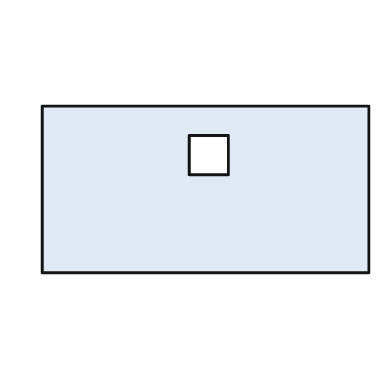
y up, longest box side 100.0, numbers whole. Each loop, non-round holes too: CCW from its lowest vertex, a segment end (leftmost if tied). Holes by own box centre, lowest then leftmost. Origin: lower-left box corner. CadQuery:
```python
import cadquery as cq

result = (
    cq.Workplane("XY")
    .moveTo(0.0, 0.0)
    .lineTo(100.0, 0.0)
    .lineTo(100.0, 51.0)
    .lineTo(0.0, 51.0)
    .close()
    .moveTo(45.0, 30.0)
    .lineTo(57.0, 30.0)
    .lineTo(57.0, 42.0)
    .lineTo(45.0, 42.0)
    .close()
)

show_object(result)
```